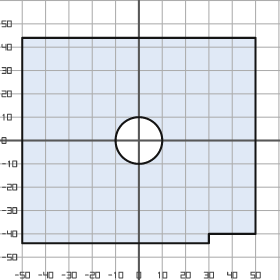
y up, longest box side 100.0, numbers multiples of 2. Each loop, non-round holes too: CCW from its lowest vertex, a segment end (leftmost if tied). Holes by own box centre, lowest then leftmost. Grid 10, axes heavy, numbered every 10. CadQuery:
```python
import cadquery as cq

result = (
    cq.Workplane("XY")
    .moveTo(-50.0, -44.0)
    .lineTo(30.0, -44.0)
    .lineTo(30.0, -40.0)
    .lineTo(50.0, -40.0)
    .lineTo(50.0, 44.0)
    .lineTo(-50.0, 44.0)
    .close()
    .moveTo(0.0, 0.0)
    .circle(10.0)
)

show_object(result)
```